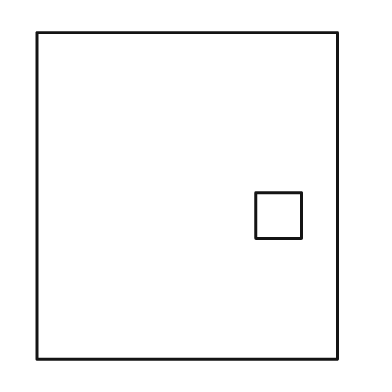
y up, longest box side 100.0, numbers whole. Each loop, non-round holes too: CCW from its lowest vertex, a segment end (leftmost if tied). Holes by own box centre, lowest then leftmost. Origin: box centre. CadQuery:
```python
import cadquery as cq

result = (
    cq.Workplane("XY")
    .moveTo(-46.0, -50.0)
    .lineTo(46.0, -50.0)
    .lineTo(46.0, 50.0)
    .lineTo(-46.0, 50.0)
    .close()
    .moveTo(21.0, -13.0)
    .lineTo(35.0, -13.0)
    .lineTo(35.0, 1.0)
    .lineTo(21.0, 1.0)
    .close()
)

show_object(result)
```